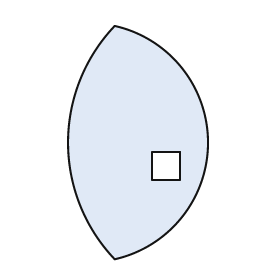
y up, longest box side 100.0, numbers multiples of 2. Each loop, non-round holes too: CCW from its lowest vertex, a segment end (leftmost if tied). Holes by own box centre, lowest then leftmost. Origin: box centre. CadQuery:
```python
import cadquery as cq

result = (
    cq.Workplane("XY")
    .moveTo(-10.0, -50.0)
    .threePointArc((30.0, 0.0), (-10.0, 50.0))
    .threePointArc((-30.0, 0.0), (-10.0, -50.0))
    .close()
    .moveTo(6.0, -16.0)
    .lineTo(18.0, -16.0)
    .lineTo(18.0, -4.0)
    .lineTo(6.0, -4.0)
    .close()
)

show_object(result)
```